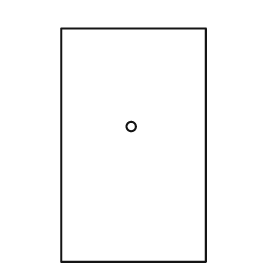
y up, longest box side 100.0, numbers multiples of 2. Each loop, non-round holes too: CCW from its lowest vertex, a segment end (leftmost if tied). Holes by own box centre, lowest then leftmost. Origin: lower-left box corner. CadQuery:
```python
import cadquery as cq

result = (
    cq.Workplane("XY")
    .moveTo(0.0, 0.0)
    .lineTo(62.0, 0.0)
    .lineTo(62.0, 100.0)
    .lineTo(0.0, 100.0)
    .close()
    .moveTo(30.0, 58.0)
    .circle(2.0)
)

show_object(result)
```